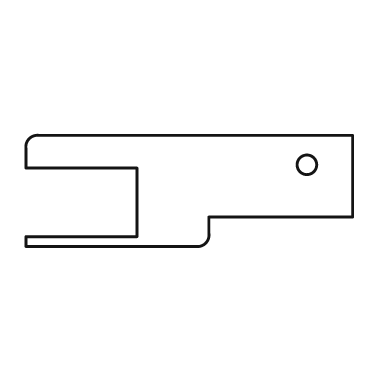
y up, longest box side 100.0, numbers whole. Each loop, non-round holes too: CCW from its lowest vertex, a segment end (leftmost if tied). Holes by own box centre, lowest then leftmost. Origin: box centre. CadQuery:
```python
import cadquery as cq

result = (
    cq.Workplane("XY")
    .moveTo(-50.0, -17.0)
    .lineTo(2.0, -17.0)
    .threePointArc((5.0, -16.0), (6.0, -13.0))
    .lineTo(6.0, -8.0)
    .lineTo(50.0, -8.0)
    .lineTo(50.0, 17.0)
    .lineTo(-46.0, 17.0)
    .threePointArc((-49.0, 16.0), (-50.0, 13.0))
    .lineTo(-50.0, 7.0)
    .lineTo(-16.0, 7.0)
    .lineTo(-16.0, -14.0)
    .lineTo(-50.0, -14.0)
    .close()
    .moveTo(36.0, 8.0)
    .circle(3.0)
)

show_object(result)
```